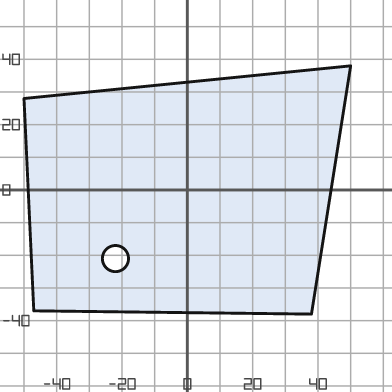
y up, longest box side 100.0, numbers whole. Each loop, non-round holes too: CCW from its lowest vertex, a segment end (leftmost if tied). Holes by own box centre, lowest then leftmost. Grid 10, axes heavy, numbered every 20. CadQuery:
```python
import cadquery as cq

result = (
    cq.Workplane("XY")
    .moveTo(38.0, -38.0)
    .lineTo(50.0, 38.0)
    .lineTo(-50.0, 28.0)
    .lineTo(-47.0, -37.0)
    .close()
    .moveTo(-22.0, -21.0)
    .circle(4.0)
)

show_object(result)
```